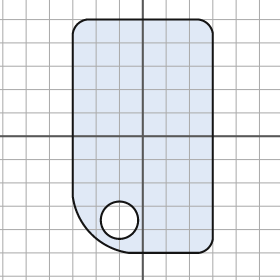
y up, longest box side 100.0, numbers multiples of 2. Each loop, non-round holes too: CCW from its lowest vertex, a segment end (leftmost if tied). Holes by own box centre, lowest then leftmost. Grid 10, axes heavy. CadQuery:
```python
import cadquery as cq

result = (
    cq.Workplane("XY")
    .moveTo(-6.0, -50.0)
    .lineTo(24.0, -50.0)
    .threePointArc((28.0, -48.0), (30.0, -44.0))
    .lineTo(30.0, 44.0)
    .threePointArc((28.0, 48.0), (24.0, 50.0))
    .lineTo(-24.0, 50.0)
    .threePointArc((-28.0, 48.0), (-30.0, 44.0))
    .lineTo(-30.0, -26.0)
    .threePointArc((-22.0, -42.0), (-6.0, -50.0))
    .close()
    .moveTo(-10.0, -36.0)
    .circle(8.0)
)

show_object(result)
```